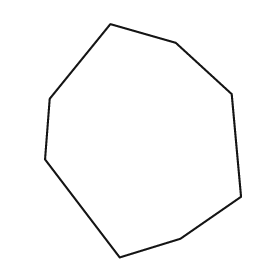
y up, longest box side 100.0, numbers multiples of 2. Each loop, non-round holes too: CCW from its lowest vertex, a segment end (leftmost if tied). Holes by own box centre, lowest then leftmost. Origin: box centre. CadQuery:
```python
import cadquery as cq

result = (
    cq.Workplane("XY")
    .moveTo(-10.0, -50.0)
    .lineTo(16.0, -42.0)
    .lineTo(42.0, -24.0)
    .lineTo(38.0, 20.0)
    .lineTo(14.0, 42.0)
    .lineTo(-14.0, 50.0)
    .lineTo(-40.0, 18.0)
    .lineTo(-42.0, -8.0)
    .close()
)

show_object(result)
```